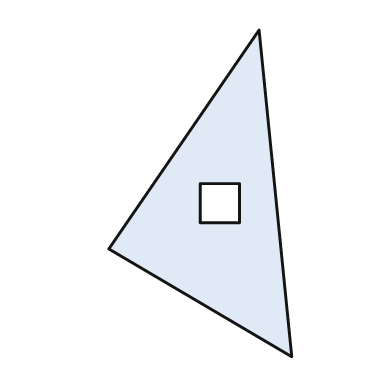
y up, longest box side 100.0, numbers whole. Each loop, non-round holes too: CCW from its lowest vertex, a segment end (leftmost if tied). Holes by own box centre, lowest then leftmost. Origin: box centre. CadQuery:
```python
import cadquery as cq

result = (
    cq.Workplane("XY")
    .moveTo(28.0, -50.0)
    .lineTo(18.0, 50.0)
    .lineTo(-28.0, -17.0)
    .close()
    .moveTo(0.0, -9.0)
    .lineTo(12.0, -9.0)
    .lineTo(12.0, 3.0)
    .lineTo(0.0, 3.0)
    .close()
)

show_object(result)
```